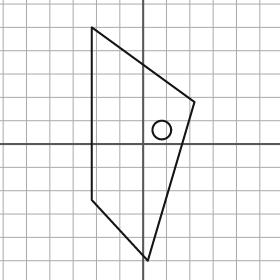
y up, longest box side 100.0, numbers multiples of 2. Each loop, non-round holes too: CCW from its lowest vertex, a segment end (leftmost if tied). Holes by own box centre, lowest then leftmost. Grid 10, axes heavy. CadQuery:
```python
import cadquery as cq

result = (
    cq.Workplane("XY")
    .moveTo(2.0, -50.0)
    .lineTo(22.0, 18.0)
    .lineTo(-22.0, 50.0)
    .lineTo(-22.0, -24.0)
    .close()
    .moveTo(8.0, 6.0)
    .circle(4.0)
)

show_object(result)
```